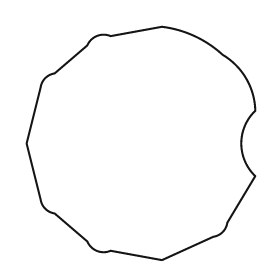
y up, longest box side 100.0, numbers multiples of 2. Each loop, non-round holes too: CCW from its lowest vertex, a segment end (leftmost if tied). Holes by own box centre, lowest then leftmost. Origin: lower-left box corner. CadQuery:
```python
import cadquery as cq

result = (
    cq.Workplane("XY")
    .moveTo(58.0, 0.0)
    .lineTo(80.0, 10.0)
    .threePointArc((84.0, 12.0), (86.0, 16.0))
    .lineTo(98.0, 36.0)
    .threePointArc((92.0, 50.0), (98.0, 64.0))
    .threePointArc((94.0, 78.0), (84.0, 88.0))
    .threePointArc((72.0, 96.0), (58.0, 100.0))
    .lineTo(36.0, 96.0)
    .threePointArc((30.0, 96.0), (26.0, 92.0))
    .lineTo(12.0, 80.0)
    .threePointArc((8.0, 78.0), (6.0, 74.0))
    .lineTo(0.0, 50.0)
    .lineTo(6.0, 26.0)
    .threePointArc((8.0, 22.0), (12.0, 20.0))
    .lineTo(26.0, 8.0)
    .threePointArc((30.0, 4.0), (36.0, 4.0))
    .close()
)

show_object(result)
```